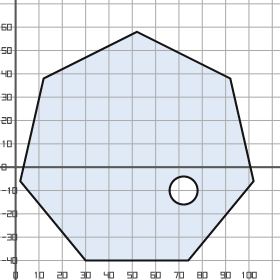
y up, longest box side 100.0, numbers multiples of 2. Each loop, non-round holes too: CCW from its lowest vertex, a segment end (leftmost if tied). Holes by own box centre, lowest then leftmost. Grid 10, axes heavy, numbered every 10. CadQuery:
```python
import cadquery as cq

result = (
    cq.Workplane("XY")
    .moveTo(30.0, -40.0)
    .lineTo(74.0, -40.0)
    .lineTo(102.0, -6.0)
    .lineTo(92.0, 38.0)
    .lineTo(52.0, 58.0)
    .lineTo(12.0, 38.0)
    .lineTo(2.0, -6.0)
    .close()
    .moveTo(72.0, -10.0)
    .circle(6.0)
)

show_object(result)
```